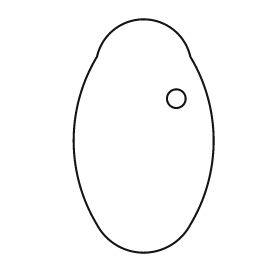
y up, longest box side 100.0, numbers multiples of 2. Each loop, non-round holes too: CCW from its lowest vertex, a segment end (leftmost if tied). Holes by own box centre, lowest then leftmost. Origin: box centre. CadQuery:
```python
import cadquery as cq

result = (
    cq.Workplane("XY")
    .moveTo(-20.0, -38.0)
    .threePointArc((0.0, -50.0), (20.0, -38.0))
    .threePointArc((30.0, -2.0), (20.0, 34.0))
    .threePointArc((0.0, 50.0), (-20.0, 34.0))
    .threePointArc((-30.0, -2.0), (-20.0, -38.0))
    .close()
    .moveTo(14.0, 16.0)
    .circle(4.0)
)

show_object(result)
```